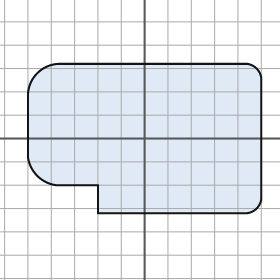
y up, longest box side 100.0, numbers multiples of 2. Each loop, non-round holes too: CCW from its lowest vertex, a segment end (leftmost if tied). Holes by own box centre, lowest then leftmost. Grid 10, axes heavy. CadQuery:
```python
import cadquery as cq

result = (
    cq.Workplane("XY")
    .moveTo(-20.0, -32.0)
    .lineTo(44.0, -32.0)
    .threePointArc((48.0, -30.0), (50.0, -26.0))
    .lineTo(50.0, 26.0)
    .threePointArc((48.0, 30.0), (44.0, 32.0))
    .lineTo(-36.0, 32.0)
    .threePointArc((-46.0, 28.0), (-50.0, 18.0))
    .lineTo(-50.0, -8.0)
    .threePointArc((-46.0, -16.0), (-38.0, -20.0))
    .lineTo(-20.0, -20.0)
    .close()
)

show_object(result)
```